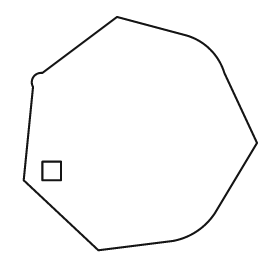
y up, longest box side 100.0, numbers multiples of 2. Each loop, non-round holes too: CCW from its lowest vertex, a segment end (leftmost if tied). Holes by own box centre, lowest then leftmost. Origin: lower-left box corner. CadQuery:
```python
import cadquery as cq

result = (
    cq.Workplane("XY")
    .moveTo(32.0, 0.0)
    .lineTo(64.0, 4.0)
    .threePointArc((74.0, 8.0), (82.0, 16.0))
    .lineTo(100.0, 46.0)
    .lineTo(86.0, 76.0)
    .threePointArc((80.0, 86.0), (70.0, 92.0))
    .lineTo(40.0, 100.0)
    .lineTo(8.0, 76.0)
    .threePointArc((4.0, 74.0), (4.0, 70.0))
    .lineTo(0.0, 30.0)
    .close()
    .moveTo(8.0, 30.0)
    .lineTo(16.0, 30.0)
    .lineTo(16.0, 38.0)
    .lineTo(8.0, 38.0)
    .close()
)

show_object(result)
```